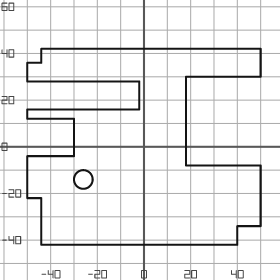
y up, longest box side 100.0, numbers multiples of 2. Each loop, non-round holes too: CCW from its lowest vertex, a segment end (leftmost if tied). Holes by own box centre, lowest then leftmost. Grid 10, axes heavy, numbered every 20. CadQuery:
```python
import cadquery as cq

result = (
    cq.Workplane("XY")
    .moveTo(-44.0, -42.0)
    .lineTo(40.0, -42.0)
    .lineTo(40.0, -34.0)
    .lineTo(50.0, -34.0)
    .lineTo(50.0, -8.0)
    .lineTo(18.0, -8.0)
    .lineTo(18.0, 30.0)
    .lineTo(50.0, 30.0)
    .lineTo(50.0, 42.0)
    .lineTo(-44.0, 42.0)
    .lineTo(-44.0, 36.0)
    .lineTo(-50.0, 36.0)
    .lineTo(-50.0, 28.0)
    .lineTo(-2.0, 28.0)
    .lineTo(-2.0, 16.0)
    .lineTo(-50.0, 16.0)
    .lineTo(-50.0, 12.0)
    .lineTo(-30.0, 12.0)
    .lineTo(-30.0, -4.0)
    .lineTo(-50.0, -4.0)
    .lineTo(-50.0, -22.0)
    .lineTo(-44.0, -22.0)
    .close()
    .moveTo(-26.0, -14.0)
    .circle(4.0)
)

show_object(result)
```